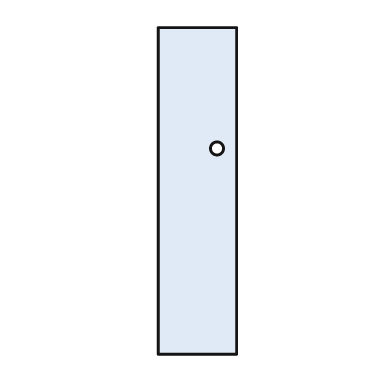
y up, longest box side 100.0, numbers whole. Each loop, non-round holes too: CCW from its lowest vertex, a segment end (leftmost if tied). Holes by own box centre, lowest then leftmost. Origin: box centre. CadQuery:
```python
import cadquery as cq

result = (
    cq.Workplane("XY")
    .moveTo(-12.0, -50.0)
    .lineTo(12.0, -50.0)
    .lineTo(12.0, 50.0)
    .lineTo(-12.0, 50.0)
    .close()
    .moveTo(6.0, 13.0)
    .circle(2.0)
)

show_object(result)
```